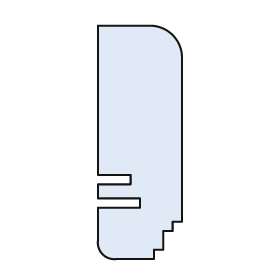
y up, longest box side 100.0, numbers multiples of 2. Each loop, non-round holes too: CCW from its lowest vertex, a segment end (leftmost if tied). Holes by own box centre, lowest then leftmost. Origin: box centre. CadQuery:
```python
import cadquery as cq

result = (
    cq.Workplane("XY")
    .moveTo(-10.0, -50.0)
    .lineTo(6.0, -50.0)
    .lineTo(6.0, -46.0)
    .lineTo(10.0, -46.0)
    .lineTo(10.0, -38.0)
    .lineTo(14.0, -38.0)
    .lineTo(14.0, -34.0)
    .lineTo(18.0, -34.0)
    .lineTo(18.0, 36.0)
    .threePointArc((14.0, 46.0), (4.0, 50.0))
    .lineTo(-18.0, 50.0)
    .lineTo(-18.0, -14.0)
    .lineTo(-4.0, -14.0)
    .lineTo(-4.0, -18.0)
    .lineTo(-18.0, -18.0)
    .lineTo(-18.0, -24.0)
    .lineTo(0.0, -24.0)
    .lineTo(0.0, -28.0)
    .lineTo(-18.0, -28.0)
    .lineTo(-18.0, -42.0)
    .threePointArc((-16.0, -48.0), (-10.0, -50.0))
    .close()
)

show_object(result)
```